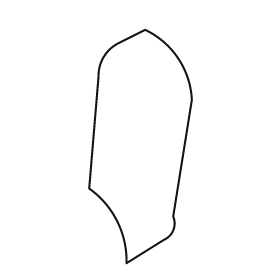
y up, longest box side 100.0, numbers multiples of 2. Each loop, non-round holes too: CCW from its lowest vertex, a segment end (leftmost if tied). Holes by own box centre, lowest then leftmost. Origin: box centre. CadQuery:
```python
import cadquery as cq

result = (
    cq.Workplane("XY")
    .moveTo(-6.0, -50.0)
    .lineTo(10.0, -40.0)
    .threePointArc((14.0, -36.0), (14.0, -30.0))
    .lineTo(22.0, 20.0)
    .threePointArc((16.0, 38.0), (2.0, 50.0))
    .lineTo(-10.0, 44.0)
    .threePointArc((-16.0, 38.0), (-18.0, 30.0))
    .lineTo(-22.0, -18.0)
    .threePointArc((-10.0, -32.0), (-6.0, -50.0))
    .close()
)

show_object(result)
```